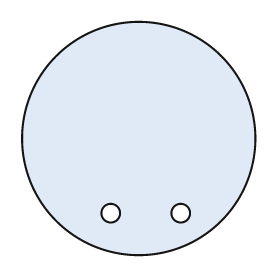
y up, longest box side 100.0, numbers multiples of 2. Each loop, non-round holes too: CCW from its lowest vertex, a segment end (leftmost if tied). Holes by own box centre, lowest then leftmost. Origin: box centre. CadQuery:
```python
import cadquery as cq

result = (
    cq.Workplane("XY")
    .moveTo(0.0, 0.0)
    .circle(50.0)
    .moveTo(-12.0, -32.0)
    .circle(4.0)
    .moveTo(18.0, -32.0)
    .circle(4.0)
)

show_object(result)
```